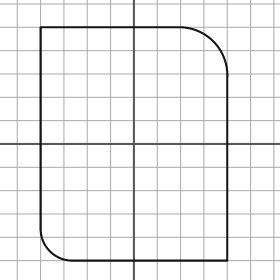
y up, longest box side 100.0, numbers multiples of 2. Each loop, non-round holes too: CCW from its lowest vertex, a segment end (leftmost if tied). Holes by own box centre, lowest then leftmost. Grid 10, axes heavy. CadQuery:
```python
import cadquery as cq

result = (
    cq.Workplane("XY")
    .moveTo(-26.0, -50.0)
    .lineTo(40.0, -50.0)
    .lineTo(40.0, 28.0)
    .threePointArc((34.0, 44.0), (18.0, 50.0))
    .lineTo(-40.0, 50.0)
    .lineTo(-40.0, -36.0)
    .threePointArc((-36.0, -46.0), (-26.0, -50.0))
    .close()
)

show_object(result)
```